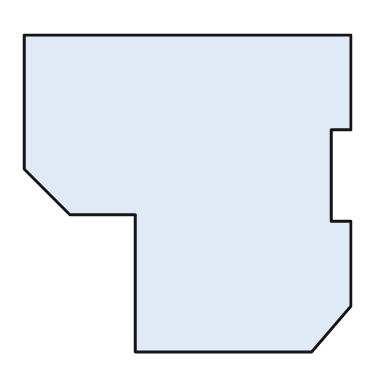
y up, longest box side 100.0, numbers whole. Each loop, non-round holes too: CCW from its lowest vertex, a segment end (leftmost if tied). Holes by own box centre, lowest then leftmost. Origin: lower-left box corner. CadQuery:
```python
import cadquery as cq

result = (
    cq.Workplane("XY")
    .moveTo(34.0, 0.0)
    .lineTo(88.0, 0.0)
    .lineTo(100.0, 14.0)
    .lineTo(100.0, 40.0)
    .lineTo(94.0, 40.0)
    .lineTo(94.0, 68.0)
    .lineTo(100.0, 68.0)
    .lineTo(100.0, 97.0)
    .lineTo(0.0, 97.0)
    .lineTo(0.0, 56.0)
    .lineTo(14.0, 42.0)
    .lineTo(34.0, 42.0)
    .close()
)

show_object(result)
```